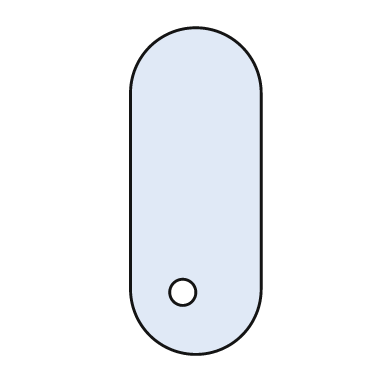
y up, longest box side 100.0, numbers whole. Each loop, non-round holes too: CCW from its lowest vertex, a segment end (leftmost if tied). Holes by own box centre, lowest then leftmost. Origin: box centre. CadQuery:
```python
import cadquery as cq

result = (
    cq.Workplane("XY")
    .moveTo(-20.0, -30.0)
    .threePointArc((0.0, -50.0), (20.0, -30.0))
    .lineTo(20.0, 30.0)
    .threePointArc((0.0, 50.0), (-20.0, 30.0))
    .close()
    .moveTo(-4.0, -31.0)
    .circle(4.0)
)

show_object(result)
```